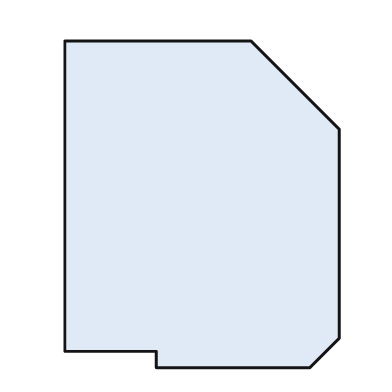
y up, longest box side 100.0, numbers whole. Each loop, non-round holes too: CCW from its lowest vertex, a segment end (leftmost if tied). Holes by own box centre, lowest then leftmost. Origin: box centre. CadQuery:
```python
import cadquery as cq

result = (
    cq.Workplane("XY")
    .moveTo(-14.0, -50.0)
    .lineTo(33.0, -50.0)
    .lineTo(42.0, -41.0)
    .lineTo(42.0, 23.0)
    .lineTo(15.0, 50.0)
    .lineTo(-42.0, 50.0)
    .lineTo(-42.0, -45.0)
    .lineTo(-14.0, -45.0)
    .close()
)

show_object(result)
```